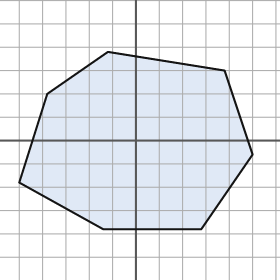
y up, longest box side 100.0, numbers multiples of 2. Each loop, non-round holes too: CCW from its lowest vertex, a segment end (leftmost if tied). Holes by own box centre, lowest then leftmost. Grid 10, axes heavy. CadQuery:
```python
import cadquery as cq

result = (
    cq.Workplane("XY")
    .moveTo(-14.0, -38.0)
    .lineTo(28.0, -38.0)
    .lineTo(50.0, -6.0)
    .lineTo(38.0, 30.0)
    .lineTo(-12.0, 38.0)
    .lineTo(-38.0, 20.0)
    .lineTo(-50.0, -18.0)
    .close()
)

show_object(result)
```